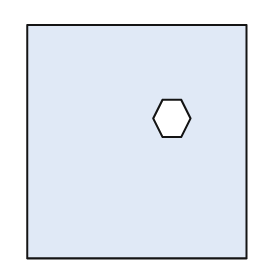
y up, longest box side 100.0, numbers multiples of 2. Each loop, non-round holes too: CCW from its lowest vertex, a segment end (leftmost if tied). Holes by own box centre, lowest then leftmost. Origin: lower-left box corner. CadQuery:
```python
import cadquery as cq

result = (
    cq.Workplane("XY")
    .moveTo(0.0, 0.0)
    .lineTo(94.0, 0.0)
    .lineTo(94.0, 100.0)
    .lineTo(0.0, 100.0)
    .close()
    .moveTo(58.0, 52.0)
    .lineTo(66.0, 52.0)
    .lineTo(70.0, 60.0)
    .lineTo(66.0, 68.0)
    .lineTo(58.0, 68.0)
    .lineTo(54.0, 60.0)
    .close()
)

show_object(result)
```